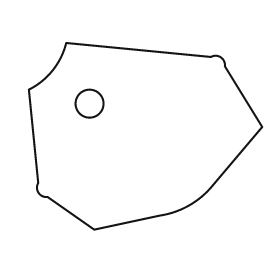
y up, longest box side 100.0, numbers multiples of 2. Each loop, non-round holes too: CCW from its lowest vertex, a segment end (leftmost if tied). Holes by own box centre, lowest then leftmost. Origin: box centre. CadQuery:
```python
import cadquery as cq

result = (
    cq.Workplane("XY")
    .moveTo(-22.0, -40.0)
    .lineTo(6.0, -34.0)
    .threePointArc((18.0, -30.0), (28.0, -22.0))
    .lineTo(50.0, 4.0)
    .lineTo(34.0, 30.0)
    .threePointArc((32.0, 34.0), (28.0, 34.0))
    .lineTo(-34.0, 40.0)
    .threePointArc((-40.0, 28.0), (-50.0, 20.0))
    .lineTo(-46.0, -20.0)
    .threePointArc((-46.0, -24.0), (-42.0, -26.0))
    .close()
    .moveTo(-24.0, 14.0)
    .circle(6.0)
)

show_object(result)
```